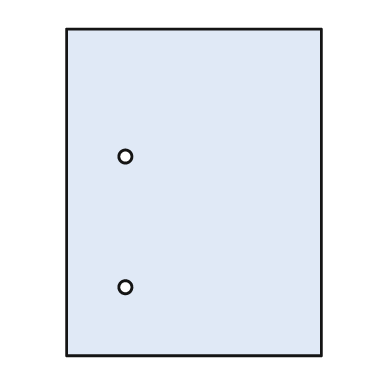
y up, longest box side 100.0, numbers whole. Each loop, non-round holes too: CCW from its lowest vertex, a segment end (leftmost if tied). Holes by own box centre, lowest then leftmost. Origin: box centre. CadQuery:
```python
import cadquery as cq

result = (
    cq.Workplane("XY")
    .moveTo(-39.0, -50.0)
    .lineTo(39.0, -50.0)
    .lineTo(39.0, 50.0)
    .lineTo(-39.0, 50.0)
    .close()
    .moveTo(-21.0, -29.0)
    .circle(2.0)
    .moveTo(-21.0, 11.0)
    .circle(2.0)
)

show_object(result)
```